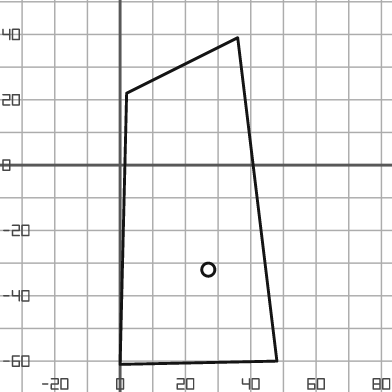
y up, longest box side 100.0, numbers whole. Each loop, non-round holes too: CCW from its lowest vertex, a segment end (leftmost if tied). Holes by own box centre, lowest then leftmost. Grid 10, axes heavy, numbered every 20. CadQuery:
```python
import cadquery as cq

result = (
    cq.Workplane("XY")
    .moveTo(0.0, -61.0)
    .lineTo(48.0, -60.0)
    .lineTo(36.0, 39.0)
    .lineTo(2.0, 22.0)
    .close()
    .moveTo(27.0, -32.0)
    .circle(2.0)
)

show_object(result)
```